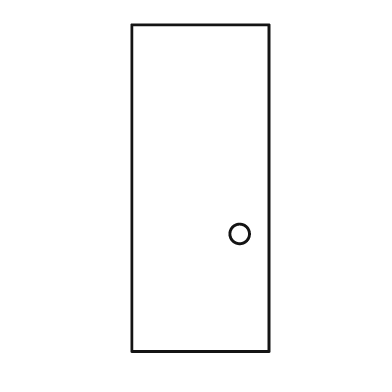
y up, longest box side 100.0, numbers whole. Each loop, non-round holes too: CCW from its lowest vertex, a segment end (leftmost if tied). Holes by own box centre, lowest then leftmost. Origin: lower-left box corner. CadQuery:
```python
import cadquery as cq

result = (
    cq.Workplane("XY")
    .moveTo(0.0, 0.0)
    .lineTo(42.0, 0.0)
    .lineTo(42.0, 100.0)
    .lineTo(0.0, 100.0)
    .close()
    .moveTo(33.0, 36.0)
    .circle(3.0)
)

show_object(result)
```